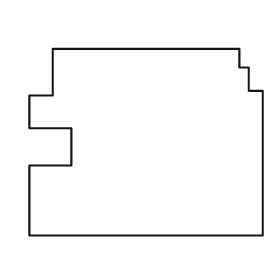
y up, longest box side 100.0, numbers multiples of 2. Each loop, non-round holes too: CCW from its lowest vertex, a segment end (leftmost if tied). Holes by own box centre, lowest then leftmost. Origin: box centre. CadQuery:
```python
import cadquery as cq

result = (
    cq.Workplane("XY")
    .moveTo(-50.0, -40.0)
    .lineTo(50.0, -40.0)
    .lineTo(50.0, 22.0)
    .lineTo(44.0, 22.0)
    .lineTo(44.0, 32.0)
    .lineTo(40.0, 32.0)
    .lineTo(40.0, 40.0)
    .lineTo(-40.0, 40.0)
    .lineTo(-40.0, 20.0)
    .lineTo(-50.0, 20.0)
    .lineTo(-50.0, 6.0)
    .lineTo(-32.0, 6.0)
    .lineTo(-32.0, -10.0)
    .lineTo(-50.0, -10.0)
    .close()
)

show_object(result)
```